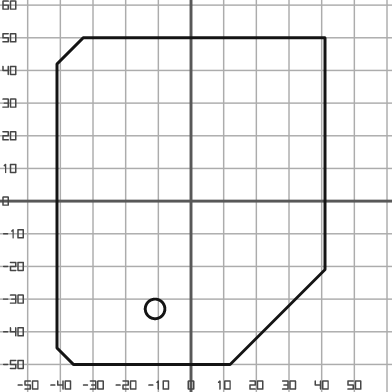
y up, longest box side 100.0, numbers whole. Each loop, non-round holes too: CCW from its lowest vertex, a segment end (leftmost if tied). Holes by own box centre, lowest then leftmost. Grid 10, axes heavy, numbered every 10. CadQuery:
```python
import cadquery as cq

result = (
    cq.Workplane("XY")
    .moveTo(-36.0, -50.0)
    .lineTo(12.0, -50.0)
    .lineTo(41.0, -21.0)
    .lineTo(41.0, 50.0)
    .lineTo(-33.0, 50.0)
    .lineTo(-41.0, 42.0)
    .lineTo(-41.0, -45.0)
    .close()
    .moveTo(-11.0, -33.0)
    .circle(3.0)
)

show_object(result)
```